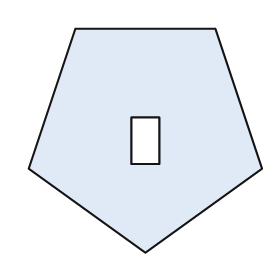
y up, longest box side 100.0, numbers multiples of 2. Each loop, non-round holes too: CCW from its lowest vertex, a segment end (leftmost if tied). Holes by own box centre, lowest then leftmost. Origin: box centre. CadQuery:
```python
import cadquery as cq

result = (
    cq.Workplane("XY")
    .moveTo(0.0, -48.0)
    .lineTo(50.0, -12.0)
    .lineTo(30.0, 48.0)
    .lineTo(-30.0, 48.0)
    .lineTo(-50.0, -12.0)
    .close()
    .moveTo(-6.0, -10.0)
    .lineTo(6.0, -10.0)
    .lineTo(6.0, 10.0)
    .lineTo(-6.0, 10.0)
    .close()
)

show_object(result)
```